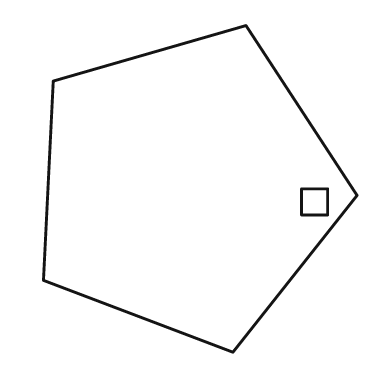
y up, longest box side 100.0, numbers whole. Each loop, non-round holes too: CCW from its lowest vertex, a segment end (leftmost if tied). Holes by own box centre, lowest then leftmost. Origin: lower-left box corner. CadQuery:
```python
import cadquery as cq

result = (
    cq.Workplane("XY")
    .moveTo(58.0, 0.0)
    .lineTo(96.0, 48.0)
    .lineTo(62.0, 100.0)
    .lineTo(3.0, 83.0)
    .lineTo(0.0, 22.0)
    .close()
    .moveTo(79.0, 42.0)
    .lineTo(87.0, 42.0)
    .lineTo(87.0, 50.0)
    .lineTo(79.0, 50.0)
    .close()
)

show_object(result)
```